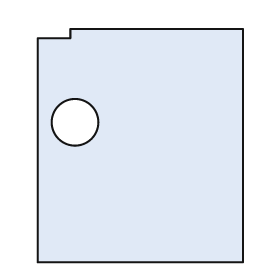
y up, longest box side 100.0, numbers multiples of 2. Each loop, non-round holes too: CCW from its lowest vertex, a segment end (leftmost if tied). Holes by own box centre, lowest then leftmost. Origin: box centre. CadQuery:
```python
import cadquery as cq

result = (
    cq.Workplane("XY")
    .moveTo(-44.0, -50.0)
    .lineTo(44.0, -50.0)
    .lineTo(44.0, 50.0)
    .lineTo(-30.0, 50.0)
    .lineTo(-30.0, 46.0)
    .lineTo(-44.0, 46.0)
    .close()
    .moveTo(-28.0, 10.0)
    .circle(10.0)
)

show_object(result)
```